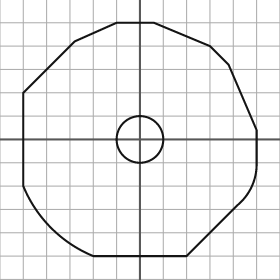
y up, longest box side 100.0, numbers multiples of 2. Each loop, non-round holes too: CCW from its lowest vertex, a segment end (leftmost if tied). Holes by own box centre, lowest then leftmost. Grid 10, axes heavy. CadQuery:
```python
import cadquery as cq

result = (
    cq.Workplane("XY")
    .moveTo(-20.0, -50.0)
    .lineTo(20.0, -50.0)
    .lineTo(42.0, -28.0)
    .threePointArc((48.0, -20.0), (50.0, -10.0))
    .lineTo(50.0, 4.0)
    .lineTo(38.0, 32.0)
    .lineTo(30.0, 40.0)
    .lineTo(6.0, 50.0)
    .lineTo(-10.0, 50.0)
    .lineTo(-28.0, 42.0)
    .lineTo(-50.0, 20.0)
    .lineTo(-50.0, -20.0)
    .threePointArc((-38.0, -38.0), (-20.0, -50.0))
    .close()
    .moveTo(0.0, 0.0)
    .circle(10.0)
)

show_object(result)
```